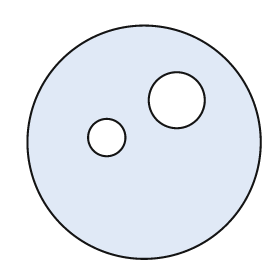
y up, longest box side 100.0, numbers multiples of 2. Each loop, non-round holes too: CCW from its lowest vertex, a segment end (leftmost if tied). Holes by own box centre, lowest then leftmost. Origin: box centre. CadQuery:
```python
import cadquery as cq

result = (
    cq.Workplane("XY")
    .moveTo(0.0, 0.0)
    .circle(50.0)
    .moveTo(-16.0, 2.0)
    .circle(8.0)
    .moveTo(14.0, 18.0)
    .circle(12.0)
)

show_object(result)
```